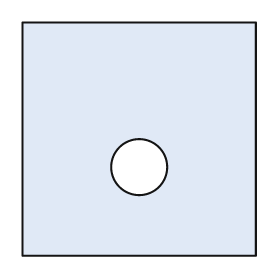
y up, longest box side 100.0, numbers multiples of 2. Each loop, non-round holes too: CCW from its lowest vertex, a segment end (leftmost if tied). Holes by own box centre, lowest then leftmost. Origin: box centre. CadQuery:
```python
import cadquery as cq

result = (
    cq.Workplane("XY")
    .moveTo(-50.0, -50.0)
    .lineTo(50.0, -50.0)
    .lineTo(50.0, 50.0)
    .lineTo(-50.0, 50.0)
    .close()
    .moveTo(0.0, -12.0)
    .circle(12.0)
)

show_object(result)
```